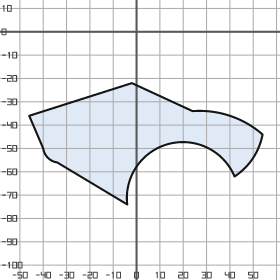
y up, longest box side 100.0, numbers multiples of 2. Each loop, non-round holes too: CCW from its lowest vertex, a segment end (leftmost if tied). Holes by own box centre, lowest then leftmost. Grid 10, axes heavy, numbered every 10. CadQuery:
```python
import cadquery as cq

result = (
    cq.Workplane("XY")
    .moveTo(-4.0, -74.0)
    .threePointArc((14.0, -48.0), (42.0, -62.0))
    .threePointArc((50.0, -54.0), (54.0, -44.0))
    .threePointArc((40.0, -36.0), (24.0, -34.0))
    .lineTo(-2.0, -22.0)
    .lineTo(-46.0, -36.0)
    .lineTo(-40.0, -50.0)
    .threePointArc((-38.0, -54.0), (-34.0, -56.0))
    .close()
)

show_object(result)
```